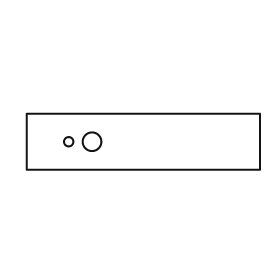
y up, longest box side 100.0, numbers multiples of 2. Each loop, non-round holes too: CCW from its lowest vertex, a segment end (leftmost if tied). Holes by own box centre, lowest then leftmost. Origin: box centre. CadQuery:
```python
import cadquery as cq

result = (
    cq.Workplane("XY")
    .moveTo(-50.0, -12.0)
    .lineTo(50.0, -12.0)
    .lineTo(50.0, 12.0)
    .lineTo(-50.0, 12.0)
    .close()
    .moveTo(-32.0, 0.0)
    .circle(2.0)
    .moveTo(-22.0, 0.0)
    .circle(4.0)
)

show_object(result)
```